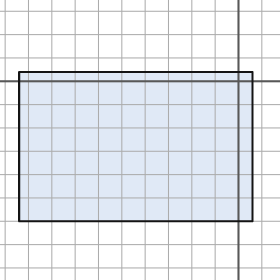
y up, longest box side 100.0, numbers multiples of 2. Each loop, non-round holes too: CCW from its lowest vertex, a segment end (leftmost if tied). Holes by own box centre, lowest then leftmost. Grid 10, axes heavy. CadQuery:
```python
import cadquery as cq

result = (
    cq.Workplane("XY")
    .moveTo(-94.0, -60.0)
    .lineTo(6.0, -60.0)
    .lineTo(6.0, 4.0)
    .lineTo(-94.0, 4.0)
    .close()
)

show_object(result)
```